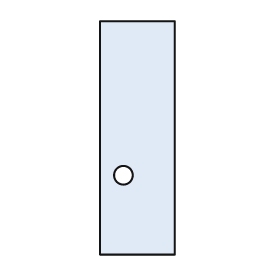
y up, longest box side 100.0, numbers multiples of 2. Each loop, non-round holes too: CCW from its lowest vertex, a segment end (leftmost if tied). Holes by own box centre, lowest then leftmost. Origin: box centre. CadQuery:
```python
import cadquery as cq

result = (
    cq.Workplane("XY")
    .moveTo(-16.0, -50.0)
    .lineTo(16.0, -50.0)
    .lineTo(16.0, 50.0)
    .lineTo(-16.0, 50.0)
    .close()
    .moveTo(-6.0, -16.0)
    .circle(4.0)
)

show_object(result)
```